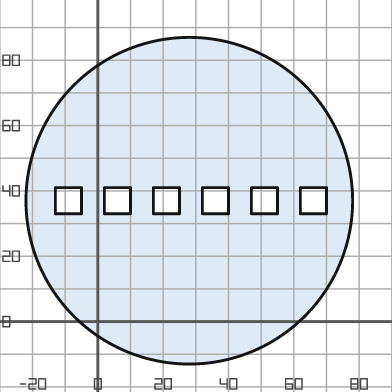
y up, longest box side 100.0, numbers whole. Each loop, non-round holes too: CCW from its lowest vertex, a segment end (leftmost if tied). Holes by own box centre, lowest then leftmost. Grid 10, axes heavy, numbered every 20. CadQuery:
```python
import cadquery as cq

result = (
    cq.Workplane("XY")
    .moveTo(28.0, 37.0)
    .circle(50.0)
    .moveTo(-13.0, 33.0)
    .lineTo(-5.0, 33.0)
    .lineTo(-5.0, 41.0)
    .lineTo(-13.0, 41.0)
    .close()
    .moveTo(2.0, 33.0)
    .lineTo(10.0, 33.0)
    .lineTo(10.0, 41.0)
    .lineTo(2.0, 41.0)
    .close()
    .moveTo(17.0, 33.0)
    .lineTo(25.0, 33.0)
    .lineTo(25.0, 41.0)
    .lineTo(17.0, 41.0)
    .close()
    .moveTo(32.0, 33.0)
    .lineTo(40.0, 33.0)
    .lineTo(40.0, 41.0)
    .lineTo(32.0, 41.0)
    .close()
    .moveTo(47.0, 33.0)
    .lineTo(55.0, 33.0)
    .lineTo(55.0, 41.0)
    .lineTo(47.0, 41.0)
    .close()
    .moveTo(62.0, 33.0)
    .lineTo(70.0, 33.0)
    .lineTo(70.0, 41.0)
    .lineTo(62.0, 41.0)
    .close()
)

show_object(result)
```